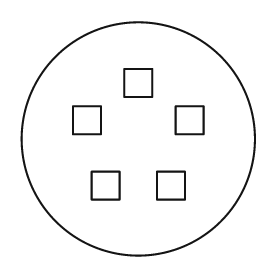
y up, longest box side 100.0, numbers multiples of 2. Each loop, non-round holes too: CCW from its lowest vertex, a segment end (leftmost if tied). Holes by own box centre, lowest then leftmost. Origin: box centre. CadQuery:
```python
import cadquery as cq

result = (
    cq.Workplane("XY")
    .moveTo(0.0, 0.0)
    .circle(50.0)
    .moveTo(-20.0, -26.0)
    .lineTo(-8.0, -26.0)
    .lineTo(-8.0, -14.0)
    .lineTo(-20.0, -14.0)
    .close()
    .moveTo(8.0, -26.0)
    .lineTo(20.0, -26.0)
    .lineTo(20.0, -14.0)
    .lineTo(8.0, -14.0)
    .close()
    .moveTo(-28.0, 2.0)
    .lineTo(-16.0, 2.0)
    .lineTo(-16.0, 14.0)
    .lineTo(-28.0, 14.0)
    .close()
    .moveTo(16.0, 2.0)
    .lineTo(28.0, 2.0)
    .lineTo(28.0, 14.0)
    .lineTo(16.0, 14.0)
    .close()
    .moveTo(-6.0, 18.0)
    .lineTo(6.0, 18.0)
    .lineTo(6.0, 30.0)
    .lineTo(-6.0, 30.0)
    .close()
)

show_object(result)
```